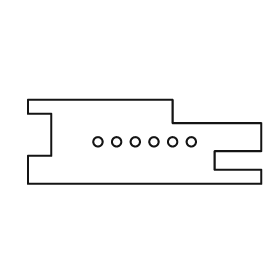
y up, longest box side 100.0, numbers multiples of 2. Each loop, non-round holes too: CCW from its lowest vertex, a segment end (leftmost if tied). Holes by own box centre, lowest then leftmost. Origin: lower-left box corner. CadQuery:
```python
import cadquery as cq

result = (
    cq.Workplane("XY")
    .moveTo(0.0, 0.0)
    .lineTo(100.0, 0.0)
    .lineTo(100.0, 6.0)
    .lineTo(80.0, 6.0)
    .lineTo(80.0, 14.0)
    .lineTo(100.0, 14.0)
    .lineTo(100.0, 26.0)
    .lineTo(62.0, 26.0)
    .lineTo(62.0, 36.0)
    .lineTo(0.0, 36.0)
    .lineTo(0.0, 30.0)
    .lineTo(10.0, 30.0)
    .lineTo(10.0, 12.0)
    .lineTo(0.0, 12.0)
    .close()
    .moveTo(30.0, 18.0)
    .circle(2.0)
    .moveTo(38.0, 18.0)
    .circle(2.0)
    .moveTo(46.0, 18.0)
    .circle(2.0)
    .moveTo(54.0, 18.0)
    .circle(2.0)
    .moveTo(62.0, 18.0)
    .circle(2.0)
    .moveTo(70.0, 18.0)
    .circle(2.0)
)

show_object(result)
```